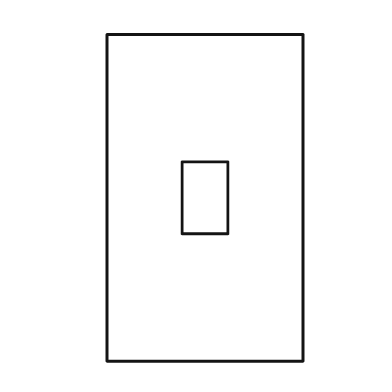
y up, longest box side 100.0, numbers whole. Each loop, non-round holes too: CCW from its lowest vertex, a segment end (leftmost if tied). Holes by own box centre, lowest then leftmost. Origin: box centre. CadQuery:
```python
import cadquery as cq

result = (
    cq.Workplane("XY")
    .moveTo(-30.0, -50.0)
    .lineTo(30.0, -50.0)
    .lineTo(30.0, 50.0)
    .lineTo(-30.0, 50.0)
    .close()
    .moveTo(-7.0, -11.0)
    .lineTo(7.0, -11.0)
    .lineTo(7.0, 11.0)
    .lineTo(-7.0, 11.0)
    .close()
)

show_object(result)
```